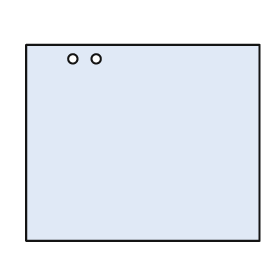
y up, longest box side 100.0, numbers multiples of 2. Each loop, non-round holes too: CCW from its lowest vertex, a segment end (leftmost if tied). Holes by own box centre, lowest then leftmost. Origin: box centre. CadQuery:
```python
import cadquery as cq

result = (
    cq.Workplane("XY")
    .moveTo(-50.0, -42.0)
    .lineTo(50.0, -42.0)
    .lineTo(50.0, 42.0)
    .lineTo(-50.0, 42.0)
    .close()
    .moveTo(-30.0, 36.0)
    .circle(2.0)
    .moveTo(-20.0, 36.0)
    .circle(2.0)
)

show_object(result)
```